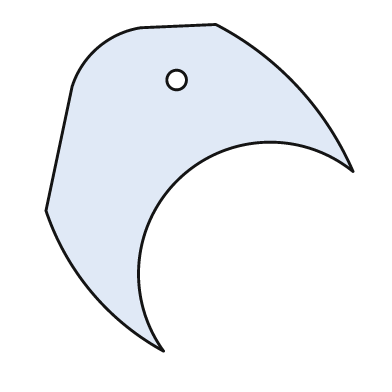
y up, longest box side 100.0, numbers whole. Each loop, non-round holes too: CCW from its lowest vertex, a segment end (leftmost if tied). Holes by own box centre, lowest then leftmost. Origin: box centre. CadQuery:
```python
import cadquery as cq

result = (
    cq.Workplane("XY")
    .moveTo(-11.0, -50.0)
    .threePointArc((-6.0, 3.0), (47.0, 5.0))
    .threePointArc((30.0, 31.0), (5.0, 50.0))
    .lineTo(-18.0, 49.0)
    .threePointArc((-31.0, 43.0), (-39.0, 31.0))
    .lineTo(-47.0, -7.0)
    .threePointArc((-33.0, -32.0), (-11.0, -50.0))
    .close()
    .moveTo(-7.0, 33.0)
    .circle(3.0)
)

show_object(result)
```